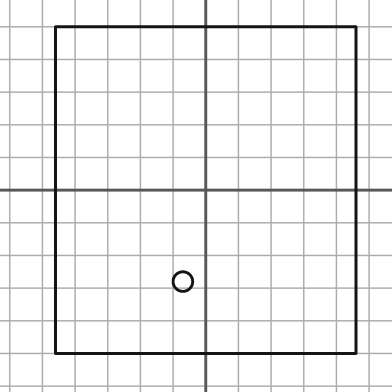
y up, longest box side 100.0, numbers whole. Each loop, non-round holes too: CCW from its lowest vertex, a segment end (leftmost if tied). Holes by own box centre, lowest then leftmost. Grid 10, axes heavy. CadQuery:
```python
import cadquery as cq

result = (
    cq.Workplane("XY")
    .moveTo(-46.0, -50.0)
    .lineTo(46.0, -50.0)
    .lineTo(46.0, 50.0)
    .lineTo(-46.0, 50.0)
    .close()
    .moveTo(-7.0, -28.0)
    .circle(3.0)
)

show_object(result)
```